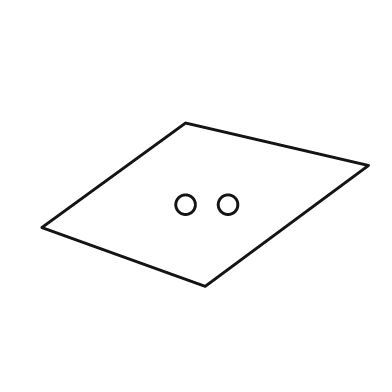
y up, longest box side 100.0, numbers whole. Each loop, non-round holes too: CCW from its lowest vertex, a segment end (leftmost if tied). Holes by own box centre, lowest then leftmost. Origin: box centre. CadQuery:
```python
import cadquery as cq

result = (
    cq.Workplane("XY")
    .moveTo(0.0, -25.0)
    .lineTo(50.0, 12.0)
    .lineTo(-6.0, 25.0)
    .lineTo(-50.0, -7.0)
    .close()
    .moveTo(-6.0, 0.0)
    .circle(3.0)
    .moveTo(7.0, 0.0)
    .circle(3.0)
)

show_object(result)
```